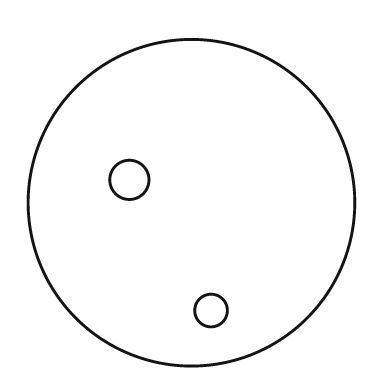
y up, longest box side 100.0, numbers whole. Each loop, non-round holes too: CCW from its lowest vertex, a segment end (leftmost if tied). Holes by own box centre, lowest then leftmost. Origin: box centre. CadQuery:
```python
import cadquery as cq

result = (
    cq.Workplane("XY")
    .moveTo(0.0, 0.0)
    .circle(50.0)
    .moveTo(6.0, -33.0)
    .circle(5.0)
    .moveTo(-19.0, 7.0)
    .circle(6.0)
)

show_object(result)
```